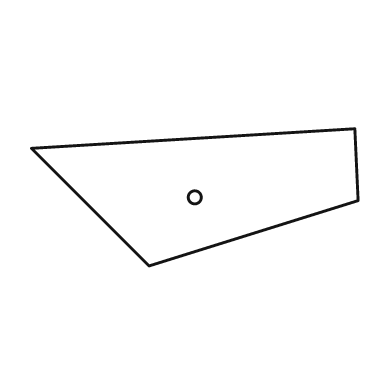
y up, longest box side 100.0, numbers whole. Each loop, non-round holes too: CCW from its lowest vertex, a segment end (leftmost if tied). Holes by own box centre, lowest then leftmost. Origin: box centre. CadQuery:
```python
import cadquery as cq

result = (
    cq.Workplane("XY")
    .moveTo(-14.0, -21.0)
    .lineTo(50.0, -1.0)
    .lineTo(49.0, 21.0)
    .lineTo(-50.0, 15.0)
    .close()
    .moveTo(0.0, 0.0)
    .circle(2.0)
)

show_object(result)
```